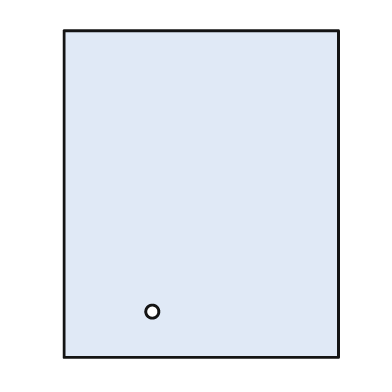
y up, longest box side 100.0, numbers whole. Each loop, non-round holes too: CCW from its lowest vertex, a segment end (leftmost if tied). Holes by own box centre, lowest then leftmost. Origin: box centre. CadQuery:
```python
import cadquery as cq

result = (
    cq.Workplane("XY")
    .moveTo(-42.0, -50.0)
    .lineTo(42.0, -50.0)
    .lineTo(42.0, 50.0)
    .lineTo(-42.0, 50.0)
    .close()
    .moveTo(-15.0, -36.0)
    .circle(2.0)
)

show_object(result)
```